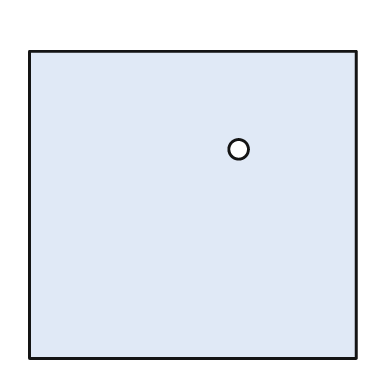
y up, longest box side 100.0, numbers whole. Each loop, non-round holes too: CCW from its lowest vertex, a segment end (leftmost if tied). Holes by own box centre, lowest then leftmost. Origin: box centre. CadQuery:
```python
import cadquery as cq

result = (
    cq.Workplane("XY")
    .moveTo(-50.0, -47.0)
    .lineTo(50.0, -47.0)
    .lineTo(50.0, 47.0)
    .lineTo(-50.0, 47.0)
    .close()
    .moveTo(14.0, 17.0)
    .circle(3.0)
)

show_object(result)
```